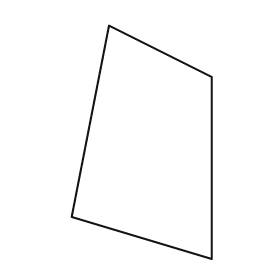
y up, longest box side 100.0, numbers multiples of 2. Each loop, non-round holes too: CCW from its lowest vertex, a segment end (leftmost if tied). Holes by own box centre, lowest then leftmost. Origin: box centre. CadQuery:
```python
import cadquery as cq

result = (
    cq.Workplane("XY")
    .moveTo(30.0, -50.0)
    .lineTo(30.0, 28.0)
    .lineTo(-14.0, 50.0)
    .lineTo(-30.0, -32.0)
    .close()
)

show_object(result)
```